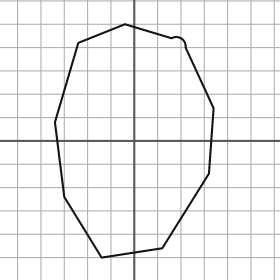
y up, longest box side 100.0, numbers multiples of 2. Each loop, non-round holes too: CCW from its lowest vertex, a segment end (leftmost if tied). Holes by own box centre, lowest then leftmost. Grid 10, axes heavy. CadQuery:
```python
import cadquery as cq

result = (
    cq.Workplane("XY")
    .moveTo(-14.0, -50.0)
    .lineTo(12.0, -46.0)
    .lineTo(32.0, -14.0)
    .lineTo(34.0, 14.0)
    .lineTo(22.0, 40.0)
    .threePointArc((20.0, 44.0), (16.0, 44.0))
    .lineTo(-4.0, 50.0)
    .lineTo(-24.0, 42.0)
    .lineTo(-34.0, 8.0)
    .lineTo(-30.0, -24.0)
    .close()
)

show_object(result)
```